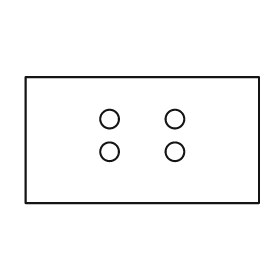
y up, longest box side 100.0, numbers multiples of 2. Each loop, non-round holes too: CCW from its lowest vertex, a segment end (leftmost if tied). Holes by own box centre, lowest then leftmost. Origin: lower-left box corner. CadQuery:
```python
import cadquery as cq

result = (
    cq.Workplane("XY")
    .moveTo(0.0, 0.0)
    .lineTo(100.0, 0.0)
    .lineTo(100.0, 54.0)
    .lineTo(0.0, 54.0)
    .close()
    .moveTo(36.0, 22.0)
    .circle(4.0)
    .moveTo(64.0, 22.0)
    .circle(4.0)
    .moveTo(36.0, 36.0)
    .circle(4.0)
    .moveTo(64.0, 36.0)
    .circle(4.0)
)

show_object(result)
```